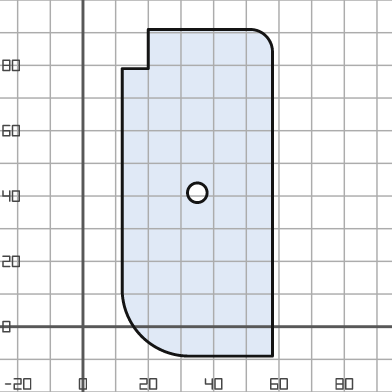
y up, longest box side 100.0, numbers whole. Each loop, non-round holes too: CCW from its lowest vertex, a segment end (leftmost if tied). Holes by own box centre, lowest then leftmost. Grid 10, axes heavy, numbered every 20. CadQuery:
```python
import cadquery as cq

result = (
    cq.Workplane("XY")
    .moveTo(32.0, -9.0)
    .lineTo(58.0, -9.0)
    .lineTo(58.0, 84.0)
    .threePointArc((56.0, 89.0), (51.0, 91.0))
    .lineTo(20.0, 91.0)
    .lineTo(20.0, 79.0)
    .lineTo(12.0, 79.0)
    .lineTo(12.0, 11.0)
    .threePointArc((18.0, -3.0), (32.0, -9.0))
    .close()
    .moveTo(35.0, 41.0)
    .circle(3.0)
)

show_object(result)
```